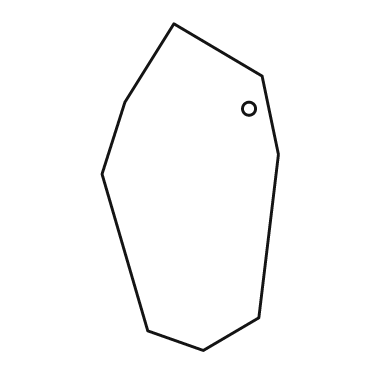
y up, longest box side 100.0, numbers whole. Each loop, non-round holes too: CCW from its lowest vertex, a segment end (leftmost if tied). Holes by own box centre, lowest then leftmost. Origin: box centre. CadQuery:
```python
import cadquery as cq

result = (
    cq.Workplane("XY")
    .moveTo(4.0, -50.0)
    .lineTo(21.0, -40.0)
    .lineTo(27.0, 10.0)
    .lineTo(22.0, 34.0)
    .lineTo(-5.0, 50.0)
    .lineTo(-20.0, 26.0)
    .lineTo(-27.0, 4.0)
    .lineTo(-13.0, -44.0)
    .close()
    .moveTo(18.0, 24.0)
    .circle(2.0)
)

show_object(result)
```